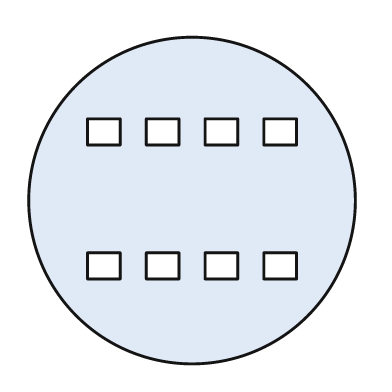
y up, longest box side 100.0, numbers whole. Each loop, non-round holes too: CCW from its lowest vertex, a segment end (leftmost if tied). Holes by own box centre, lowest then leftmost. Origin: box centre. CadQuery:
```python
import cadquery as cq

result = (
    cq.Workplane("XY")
    .moveTo(0.0, 0.0)
    .circle(50.0)
    .moveTo(-32.0, -24.0)
    .lineTo(-22.0, -24.0)
    .lineTo(-22.0, -16.0)
    .lineTo(-32.0, -16.0)
    .close()
    .moveTo(-14.0, -24.0)
    .lineTo(-4.0, -24.0)
    .lineTo(-4.0, -16.0)
    .lineTo(-14.0, -16.0)
    .close()
    .moveTo(4.0, -24.0)
    .lineTo(14.0, -24.0)
    .lineTo(14.0, -16.0)
    .lineTo(4.0, -16.0)
    .close()
    .moveTo(22.0, -24.0)
    .lineTo(32.0, -24.0)
    .lineTo(32.0, -16.0)
    .lineTo(22.0, -16.0)
    .close()
    .moveTo(-32.0, 17.0)
    .lineTo(-22.0, 17.0)
    .lineTo(-22.0, 25.0)
    .lineTo(-32.0, 25.0)
    .close()
    .moveTo(-14.0, 17.0)
    .lineTo(-4.0, 17.0)
    .lineTo(-4.0, 25.0)
    .lineTo(-14.0, 25.0)
    .close()
    .moveTo(4.0, 17.0)
    .lineTo(14.0, 17.0)
    .lineTo(14.0, 25.0)
    .lineTo(4.0, 25.0)
    .close()
    .moveTo(22.0, 17.0)
    .lineTo(32.0, 17.0)
    .lineTo(32.0, 25.0)
    .lineTo(22.0, 25.0)
    .close()
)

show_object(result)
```